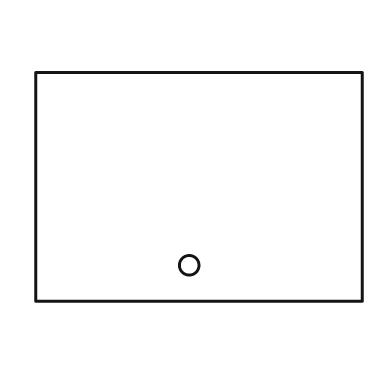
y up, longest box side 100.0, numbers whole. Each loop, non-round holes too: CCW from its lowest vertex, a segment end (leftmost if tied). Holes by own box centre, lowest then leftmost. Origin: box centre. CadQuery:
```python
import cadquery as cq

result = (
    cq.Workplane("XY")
    .moveTo(-50.0, -35.0)
    .lineTo(50.0, -35.0)
    .lineTo(50.0, 35.0)
    .lineTo(-50.0, 35.0)
    .close()
    .moveTo(-3.0, -24.0)
    .circle(3.0)
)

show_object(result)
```